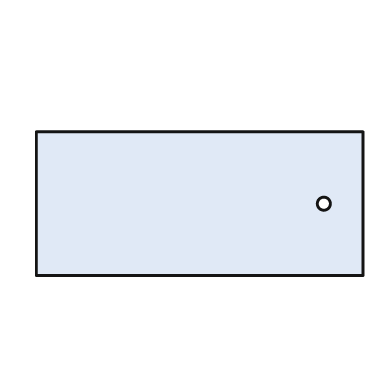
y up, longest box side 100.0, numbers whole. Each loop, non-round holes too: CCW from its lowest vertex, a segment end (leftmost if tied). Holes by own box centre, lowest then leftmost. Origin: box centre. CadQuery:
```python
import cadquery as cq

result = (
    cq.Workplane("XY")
    .moveTo(-50.0, -22.0)
    .lineTo(50.0, -22.0)
    .lineTo(50.0, 22.0)
    .lineTo(-50.0, 22.0)
    .close()
    .moveTo(38.0, 0.0)
    .circle(2.0)
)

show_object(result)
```